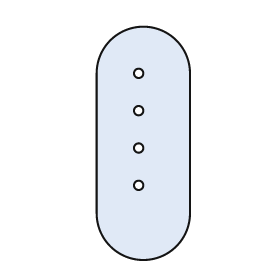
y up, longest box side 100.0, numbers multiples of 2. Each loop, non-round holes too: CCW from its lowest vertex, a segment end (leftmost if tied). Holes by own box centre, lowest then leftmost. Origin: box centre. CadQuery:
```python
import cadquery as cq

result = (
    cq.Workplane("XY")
    .moveTo(-20.0, -30.0)
    .threePointArc((0.0, -50.0), (20.0, -30.0))
    .lineTo(20.0, 30.0)
    .threePointArc((0.0, 50.0), (-20.0, 30.0))
    .close()
    .moveTo(-2.0, -18.0)
    .circle(2.0)
    .moveTo(-2.0, -2.0)
    .circle(2.0)
    .moveTo(-2.0, 14.0)
    .circle(2.0)
    .moveTo(-2.0, 30.0)
    .circle(2.0)
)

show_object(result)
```